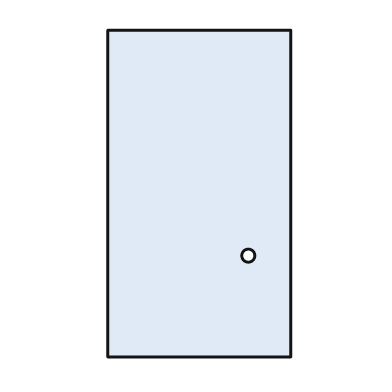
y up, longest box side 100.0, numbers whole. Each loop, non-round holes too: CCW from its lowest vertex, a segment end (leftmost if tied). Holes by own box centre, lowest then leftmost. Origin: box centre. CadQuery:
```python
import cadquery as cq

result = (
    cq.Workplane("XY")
    .moveTo(-28.0, -50.0)
    .lineTo(28.0, -50.0)
    .lineTo(28.0, 50.0)
    .lineTo(-28.0, 50.0)
    .close()
    .moveTo(15.0, -19.0)
    .circle(2.0)
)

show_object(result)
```